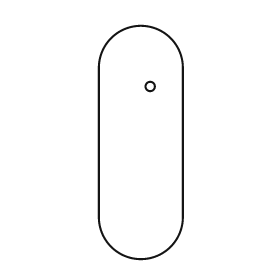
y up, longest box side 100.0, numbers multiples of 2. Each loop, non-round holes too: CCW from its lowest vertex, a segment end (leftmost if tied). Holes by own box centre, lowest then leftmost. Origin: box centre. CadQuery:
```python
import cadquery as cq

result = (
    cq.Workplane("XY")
    .moveTo(-18.0, -32.0)
    .threePointArc((0.0, -50.0), (18.0, -32.0))
    .lineTo(18.0, 32.0)
    .threePointArc((0.0, 50.0), (-18.0, 32.0))
    .close()
    .moveTo(4.0, 24.0)
    .circle(2.0)
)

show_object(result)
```